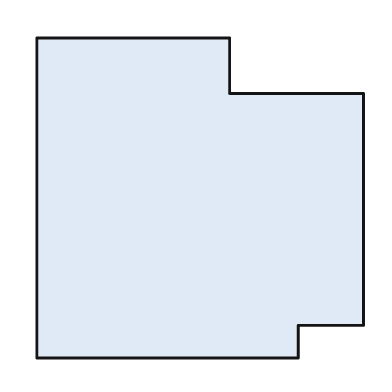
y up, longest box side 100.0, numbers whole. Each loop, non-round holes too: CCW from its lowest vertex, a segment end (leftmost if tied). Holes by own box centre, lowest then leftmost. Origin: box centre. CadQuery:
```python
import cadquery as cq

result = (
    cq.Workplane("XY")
    .moveTo(-50.0, -49.0)
    .lineTo(30.0, -49.0)
    .lineTo(30.0, -39.0)
    .lineTo(50.0, -39.0)
    .lineTo(50.0, 32.0)
    .lineTo(9.0, 32.0)
    .lineTo(9.0, 49.0)
    .lineTo(-50.0, 49.0)
    .close()
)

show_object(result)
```